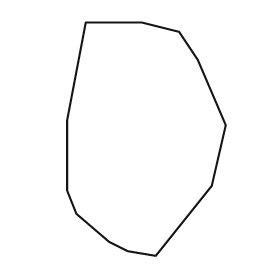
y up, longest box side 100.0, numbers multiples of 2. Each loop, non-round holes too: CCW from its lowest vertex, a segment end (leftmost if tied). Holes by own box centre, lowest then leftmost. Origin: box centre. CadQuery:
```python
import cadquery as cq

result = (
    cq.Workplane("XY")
    .moveTo(4.0, -50.0)
    .lineTo(28.0, -20.0)
    .lineTo(34.0, 6.0)
    .lineTo(22.0, 34.0)
    .lineTo(14.0, 46.0)
    .lineTo(-2.0, 50.0)
    .lineTo(-26.0, 50.0)
    .lineTo(-34.0, 8.0)
    .lineTo(-34.0, -22.0)
    .lineTo(-30.0, -32.0)
    .lineTo(-16.0, -44.0)
    .lineTo(-8.0, -48.0)
    .close()
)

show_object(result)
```